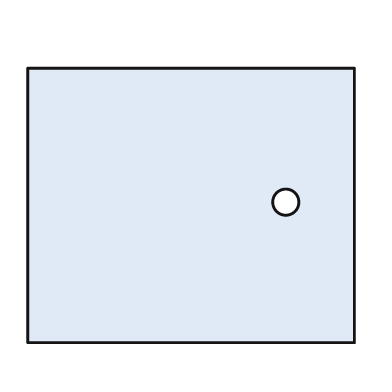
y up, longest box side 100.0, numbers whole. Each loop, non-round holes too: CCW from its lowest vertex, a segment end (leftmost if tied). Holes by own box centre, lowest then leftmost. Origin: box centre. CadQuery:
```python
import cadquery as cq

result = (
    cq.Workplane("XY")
    .moveTo(-50.0, -42.0)
    .lineTo(50.0, -42.0)
    .lineTo(50.0, 42.0)
    .lineTo(-50.0, 42.0)
    .close()
    .moveTo(29.0, 1.0)
    .circle(4.0)
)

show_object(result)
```